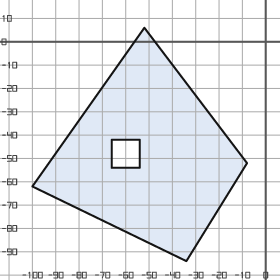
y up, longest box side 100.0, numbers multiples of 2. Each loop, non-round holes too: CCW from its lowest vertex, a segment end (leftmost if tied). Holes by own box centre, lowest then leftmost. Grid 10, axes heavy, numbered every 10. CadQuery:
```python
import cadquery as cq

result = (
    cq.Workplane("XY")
    .moveTo(-34.0, -94.0)
    .lineTo(-8.0, -52.0)
    .lineTo(-52.0, 6.0)
    .lineTo(-100.0, -62.0)
    .close()
    .moveTo(-66.0, -54.0)
    .lineTo(-54.0, -54.0)
    .lineTo(-54.0, -42.0)
    .lineTo(-66.0, -42.0)
    .close()
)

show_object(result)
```